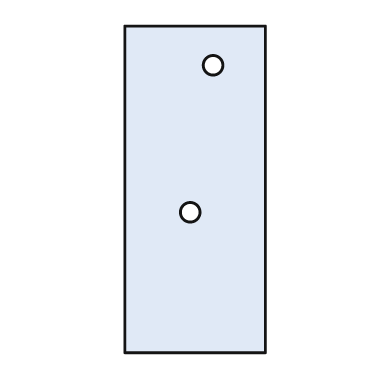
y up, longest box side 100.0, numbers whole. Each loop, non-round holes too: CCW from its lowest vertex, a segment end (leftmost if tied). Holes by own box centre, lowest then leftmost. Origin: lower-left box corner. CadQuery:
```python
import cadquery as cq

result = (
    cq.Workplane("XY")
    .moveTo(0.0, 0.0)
    .lineTo(43.0, 0.0)
    .lineTo(43.0, 100.0)
    .lineTo(0.0, 100.0)
    .close()
    .moveTo(20.0, 43.0)
    .circle(3.0)
    .moveTo(27.0, 88.0)
    .circle(3.0)
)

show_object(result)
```